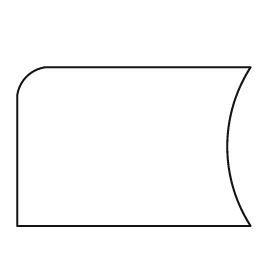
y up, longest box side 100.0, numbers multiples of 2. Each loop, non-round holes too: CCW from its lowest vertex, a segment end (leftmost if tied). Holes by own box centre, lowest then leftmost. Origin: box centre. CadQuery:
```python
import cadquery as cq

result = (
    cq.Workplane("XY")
    .moveTo(-50.0, -34.0)
    .lineTo(50.0, -34.0)
    .threePointArc((40.0, 0.0), (50.0, 34.0))
    .lineTo(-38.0, 34.0)
    .threePointArc((-46.0, 30.0), (-50.0, 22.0))
    .close()
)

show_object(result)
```